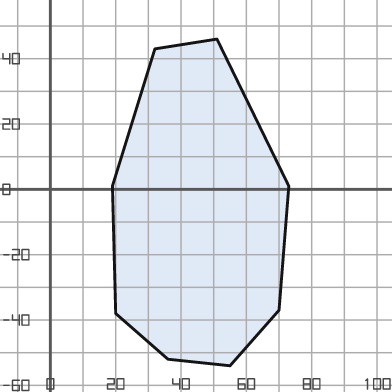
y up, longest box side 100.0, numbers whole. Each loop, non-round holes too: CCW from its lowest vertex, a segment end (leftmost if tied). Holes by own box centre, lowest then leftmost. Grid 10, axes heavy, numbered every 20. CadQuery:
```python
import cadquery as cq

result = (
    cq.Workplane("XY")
    .moveTo(55.0, -54.0)
    .lineTo(70.0, -37.0)
    .lineTo(73.0, 1.0)
    .lineTo(51.0, 46.0)
    .lineTo(32.0, 43.0)
    .lineTo(19.0, 1.0)
    .lineTo(20.0, -38.0)
    .lineTo(36.0, -52.0)
    .close()
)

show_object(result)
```